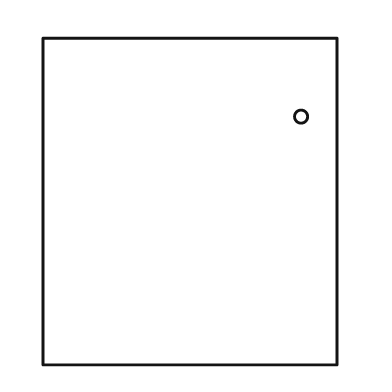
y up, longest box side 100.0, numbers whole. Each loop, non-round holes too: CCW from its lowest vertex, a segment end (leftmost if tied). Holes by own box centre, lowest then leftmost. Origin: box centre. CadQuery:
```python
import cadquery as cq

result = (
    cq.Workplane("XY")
    .moveTo(-45.0, -50.0)
    .lineTo(45.0, -50.0)
    .lineTo(45.0, 50.0)
    .lineTo(-45.0, 50.0)
    .close()
    .moveTo(34.0, 26.0)
    .circle(2.0)
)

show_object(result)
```